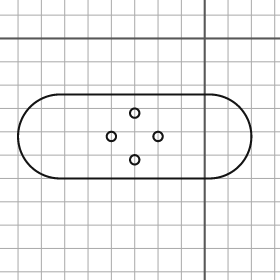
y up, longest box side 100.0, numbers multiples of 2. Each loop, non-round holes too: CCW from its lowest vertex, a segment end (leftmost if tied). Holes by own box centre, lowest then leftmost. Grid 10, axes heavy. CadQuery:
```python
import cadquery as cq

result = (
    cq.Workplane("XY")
    .moveTo(-62.0, -60.0)
    .lineTo(2.0, -60.0)
    .threePointArc((20.0, -42.0), (2.0, -24.0))
    .lineTo(-62.0, -24.0)
    .threePointArc((-80.0, -42.0), (-62.0, -60.0))
    .close()
    .moveTo(-30.0, -52.0)
    .circle(2.0)
    .moveTo(-40.0, -42.0)
    .circle(2.0)
    .moveTo(-20.0, -42.0)
    .circle(2.0)
    .moveTo(-30.0, -32.0)
    .circle(2.0)
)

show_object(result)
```